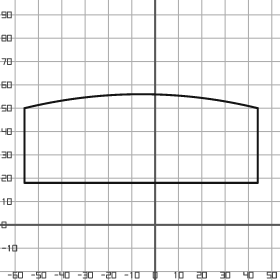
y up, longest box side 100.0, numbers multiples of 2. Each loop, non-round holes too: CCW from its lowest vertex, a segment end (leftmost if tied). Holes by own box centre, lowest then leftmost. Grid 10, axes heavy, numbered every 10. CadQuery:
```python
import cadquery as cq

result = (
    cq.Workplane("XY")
    .moveTo(-56.0, 18.0)
    .lineTo(44.0, 18.0)
    .lineTo(44.0, 50.0)
    .threePointArc((-6.0, 56.0), (-56.0, 50.0))
    .close()
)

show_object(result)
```